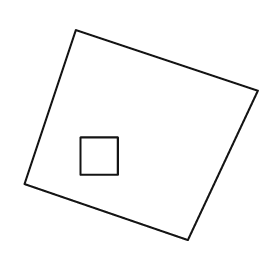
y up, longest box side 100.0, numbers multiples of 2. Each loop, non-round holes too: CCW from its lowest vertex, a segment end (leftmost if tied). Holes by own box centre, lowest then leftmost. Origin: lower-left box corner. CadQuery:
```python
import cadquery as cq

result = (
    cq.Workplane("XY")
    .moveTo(70.0, 0.0)
    .lineTo(100.0, 64.0)
    .lineTo(22.0, 90.0)
    .lineTo(0.0, 24.0)
    .close()
    .moveTo(24.0, 28.0)
    .lineTo(40.0, 28.0)
    .lineTo(40.0, 44.0)
    .lineTo(24.0, 44.0)
    .close()
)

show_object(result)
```